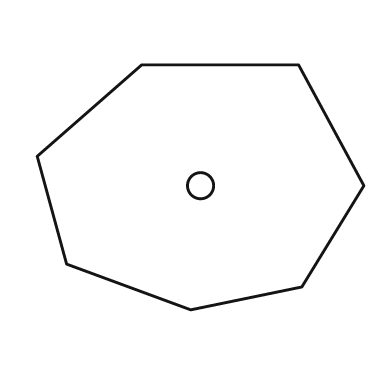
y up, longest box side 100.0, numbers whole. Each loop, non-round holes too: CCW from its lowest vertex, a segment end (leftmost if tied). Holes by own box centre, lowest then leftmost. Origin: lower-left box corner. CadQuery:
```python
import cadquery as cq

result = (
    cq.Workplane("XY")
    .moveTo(47.0, 0.0)
    .lineTo(81.0, 7.0)
    .lineTo(100.0, 38.0)
    .lineTo(80.0, 75.0)
    .lineTo(32.0, 75.0)
    .lineTo(0.0, 47.0)
    .lineTo(9.0, 14.0)
    .close()
    .moveTo(50.0, 38.0)
    .circle(4.0)
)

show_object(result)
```